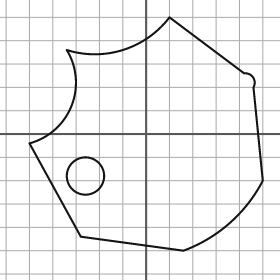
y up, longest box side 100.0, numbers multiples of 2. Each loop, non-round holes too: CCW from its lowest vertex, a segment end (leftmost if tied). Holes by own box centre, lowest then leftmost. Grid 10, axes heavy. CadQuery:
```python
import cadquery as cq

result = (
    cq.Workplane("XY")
    .moveTo(16.0, -50.0)
    .threePointArc((36.0, -38.0), (50.0, -20.0))
    .lineTo(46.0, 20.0)
    .threePointArc((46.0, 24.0), (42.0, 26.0))
    .lineTo(10.0, 50.0)
    .threePointArc((-10.0, 36.0), (-34.0, 36.0))
    .threePointArc((-32.0, 12.0), (-50.0, -4.0))
    .lineTo(-28.0, -44.0)
    .close()
    .moveTo(-26.0, -18.0)
    .circle(8.0)
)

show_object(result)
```